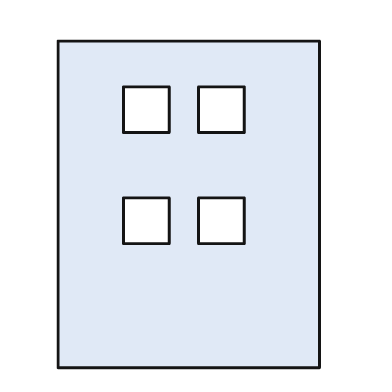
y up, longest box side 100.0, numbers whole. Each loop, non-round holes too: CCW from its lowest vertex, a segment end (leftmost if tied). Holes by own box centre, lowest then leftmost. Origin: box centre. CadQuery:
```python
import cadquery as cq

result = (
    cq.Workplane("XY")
    .moveTo(-40.0, -50.0)
    .lineTo(40.0, -50.0)
    .lineTo(40.0, 50.0)
    .lineTo(-40.0, 50.0)
    .close()
    .moveTo(-20.0, -12.0)
    .lineTo(-6.0, -12.0)
    .lineTo(-6.0, 2.0)
    .lineTo(-20.0, 2.0)
    .close()
    .moveTo(3.0, -12.0)
    .lineTo(17.0, -12.0)
    .lineTo(17.0, 2.0)
    .lineTo(3.0, 2.0)
    .close()
    .moveTo(-20.0, 22.0)
    .lineTo(-6.0, 22.0)
    .lineTo(-6.0, 36.0)
    .lineTo(-20.0, 36.0)
    .close()
    .moveTo(3.0, 22.0)
    .lineTo(17.0, 22.0)
    .lineTo(17.0, 36.0)
    .lineTo(3.0, 36.0)
    .close()
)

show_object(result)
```